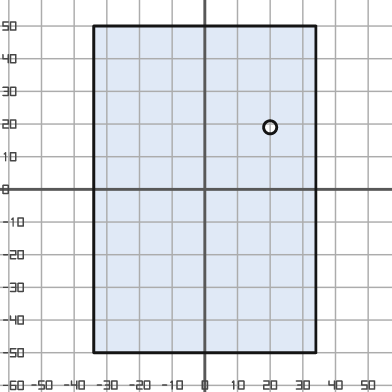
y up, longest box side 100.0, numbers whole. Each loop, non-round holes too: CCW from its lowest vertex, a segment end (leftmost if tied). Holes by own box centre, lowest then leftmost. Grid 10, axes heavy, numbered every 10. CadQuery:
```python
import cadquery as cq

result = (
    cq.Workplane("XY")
    .moveTo(-34.0, -50.0)
    .lineTo(34.0, -50.0)
    .lineTo(34.0, 50.0)
    .lineTo(-34.0, 50.0)
    .close()
    .moveTo(20.0, 19.0)
    .circle(2.0)
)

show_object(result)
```